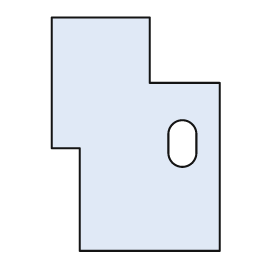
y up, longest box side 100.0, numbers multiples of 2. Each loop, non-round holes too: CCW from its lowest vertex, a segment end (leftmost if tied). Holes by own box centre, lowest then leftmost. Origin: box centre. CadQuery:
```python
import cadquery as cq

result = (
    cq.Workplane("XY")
    .moveTo(-24.0, -50.0)
    .lineTo(36.0, -50.0)
    .lineTo(36.0, 22.0)
    .lineTo(6.0, 22.0)
    .lineTo(6.0, 50.0)
    .lineTo(-36.0, 50.0)
    .lineTo(-36.0, -6.0)
    .lineTo(-24.0, -6.0)
    .close()
    .moveTo(14.0, -8.0)
    .threePointArc((20.0, -14.0), (26.0, -8.0))
    .lineTo(26.0, 0.0)
    .threePointArc((20.0, 6.0), (14.0, 0.0))
    .close()
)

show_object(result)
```